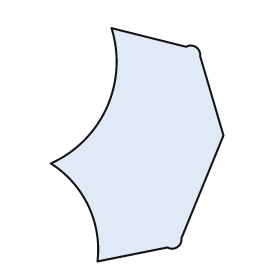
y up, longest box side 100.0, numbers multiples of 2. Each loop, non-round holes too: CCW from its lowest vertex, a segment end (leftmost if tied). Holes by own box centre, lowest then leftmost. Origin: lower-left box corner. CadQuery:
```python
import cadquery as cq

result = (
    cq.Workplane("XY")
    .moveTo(20.0, 0.0)
    .lineTo(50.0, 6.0)
    .threePointArc((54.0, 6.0), (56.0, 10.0))
    .lineTo(74.0, 54.0)
    .lineTo(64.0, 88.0)
    .threePointArc((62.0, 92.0), (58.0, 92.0))
    .lineTo(26.0, 100.0)
    .threePointArc((24.0, 66.0), (0.0, 42.0))
    .threePointArc((16.0, 24.0), (20.0, 0.0))
    .close()
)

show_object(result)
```